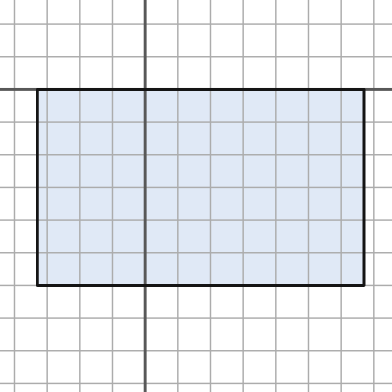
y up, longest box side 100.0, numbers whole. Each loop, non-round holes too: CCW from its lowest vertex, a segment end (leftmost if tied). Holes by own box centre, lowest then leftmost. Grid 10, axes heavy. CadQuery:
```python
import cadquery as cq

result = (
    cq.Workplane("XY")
    .moveTo(-33.0, -60.0)
    .lineTo(67.0, -60.0)
    .lineTo(67.0, 0.0)
    .lineTo(-33.0, 0.0)
    .close()
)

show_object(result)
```